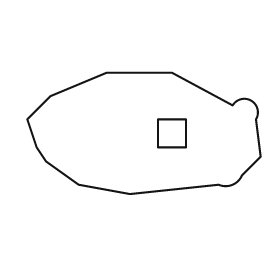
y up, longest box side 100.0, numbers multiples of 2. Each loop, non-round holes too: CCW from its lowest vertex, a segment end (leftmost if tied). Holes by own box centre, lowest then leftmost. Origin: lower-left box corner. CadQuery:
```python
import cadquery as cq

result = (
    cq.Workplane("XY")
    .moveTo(44.0, 0.0)
    .lineTo(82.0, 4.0)
    .threePointArc((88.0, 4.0), (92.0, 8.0))
    .lineTo(100.0, 16.0)
    .lineTo(98.0, 32.0)
    .threePointArc((96.0, 40.0), (88.0, 38.0))
    .lineTo(62.0, 52.0)
    .lineTo(34.0, 52.0)
    .lineTo(10.0, 42.0)
    .lineTo(0.0, 32.0)
    .lineTo(4.0, 20.0)
    .lineTo(8.0, 14.0)
    .lineTo(22.0, 4.0)
    .close()
    .moveTo(56.0, 20.0)
    .lineTo(68.0, 20.0)
    .lineTo(68.0, 32.0)
    .lineTo(56.0, 32.0)
    .close()
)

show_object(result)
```